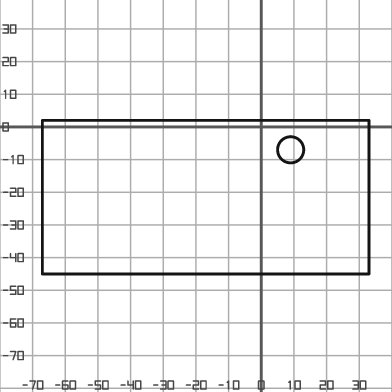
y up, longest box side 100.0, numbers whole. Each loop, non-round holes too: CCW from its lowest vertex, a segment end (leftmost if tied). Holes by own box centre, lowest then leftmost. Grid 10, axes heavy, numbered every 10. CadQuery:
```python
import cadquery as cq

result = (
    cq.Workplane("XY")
    .moveTo(-67.0, -45.0)
    .lineTo(33.0, -45.0)
    .lineTo(33.0, 2.0)
    .lineTo(-67.0, 2.0)
    .close()
    .moveTo(9.0, -7.0)
    .circle(4.0)
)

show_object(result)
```